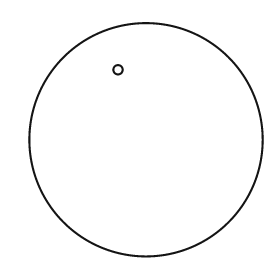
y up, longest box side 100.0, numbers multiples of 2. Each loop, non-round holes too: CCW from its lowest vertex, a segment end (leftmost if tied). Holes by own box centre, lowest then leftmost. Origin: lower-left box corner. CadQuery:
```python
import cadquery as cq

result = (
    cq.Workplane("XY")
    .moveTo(50.0, 50.0)
    .circle(50.0)
    .moveTo(38.0, 80.0)
    .circle(2.0)
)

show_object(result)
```